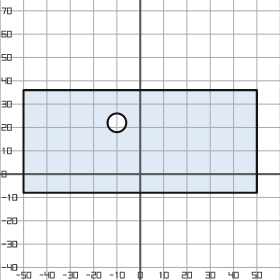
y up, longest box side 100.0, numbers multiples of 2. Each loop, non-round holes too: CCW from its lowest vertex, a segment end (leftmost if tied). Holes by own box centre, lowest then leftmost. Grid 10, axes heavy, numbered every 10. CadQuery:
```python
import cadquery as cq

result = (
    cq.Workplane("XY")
    .moveTo(-50.0, -8.0)
    .lineTo(50.0, -8.0)
    .lineTo(50.0, 36.0)
    .lineTo(-50.0, 36.0)
    .close()
    .moveTo(-10.0, 22.0)
    .circle(4.0)
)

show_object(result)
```